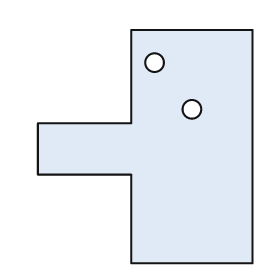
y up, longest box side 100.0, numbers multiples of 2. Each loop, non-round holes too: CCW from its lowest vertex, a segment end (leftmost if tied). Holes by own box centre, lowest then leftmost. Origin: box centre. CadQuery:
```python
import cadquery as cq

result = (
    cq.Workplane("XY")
    .moveTo(-6.0, -50.0)
    .lineTo(46.0, -50.0)
    .lineTo(46.0, 50.0)
    .lineTo(-6.0, 50.0)
    .lineTo(-6.0, 10.0)
    .lineTo(-46.0, 10.0)
    .lineTo(-46.0, -12.0)
    .lineTo(-6.0, -12.0)
    .close()
    .moveTo(20.0, 16.0)
    .circle(4.0)
    .moveTo(4.0, 36.0)
    .circle(4.0)
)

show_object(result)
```